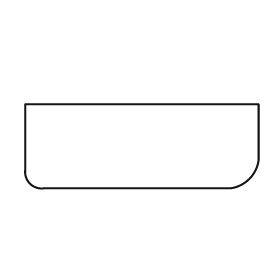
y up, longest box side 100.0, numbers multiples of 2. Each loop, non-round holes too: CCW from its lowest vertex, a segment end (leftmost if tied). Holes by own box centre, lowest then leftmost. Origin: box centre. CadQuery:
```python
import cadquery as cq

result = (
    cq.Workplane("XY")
    .moveTo(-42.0, -18.0)
    .lineTo(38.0, -18.0)
    .threePointArc((46.0, -14.0), (50.0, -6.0))
    .lineTo(50.0, 18.0)
    .lineTo(-50.0, 18.0)
    .lineTo(-50.0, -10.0)
    .threePointArc((-48.0, -16.0), (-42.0, -18.0))
    .close()
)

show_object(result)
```